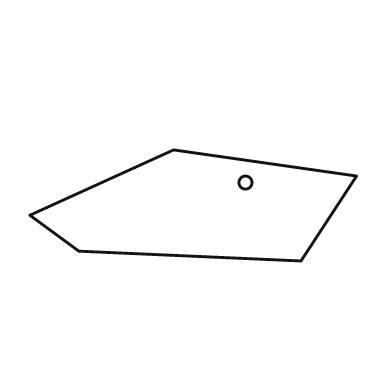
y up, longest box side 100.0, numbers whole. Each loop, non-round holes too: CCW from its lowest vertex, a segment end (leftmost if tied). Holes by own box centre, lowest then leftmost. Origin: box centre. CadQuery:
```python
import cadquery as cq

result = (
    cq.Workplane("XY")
    .moveTo(33.0, -17.0)
    .lineTo(50.0, 9.0)
    .lineTo(-6.0, 17.0)
    .lineTo(-50.0, -3.0)
    .lineTo(-35.0, -14.0)
    .close()
    .moveTo(16.0, 7.0)
    .circle(2.0)
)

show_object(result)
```